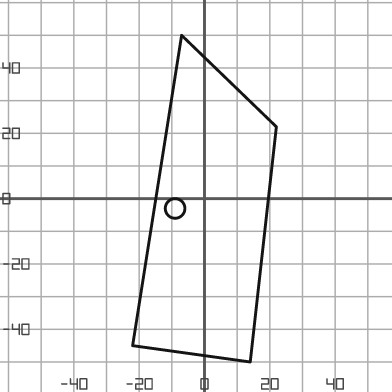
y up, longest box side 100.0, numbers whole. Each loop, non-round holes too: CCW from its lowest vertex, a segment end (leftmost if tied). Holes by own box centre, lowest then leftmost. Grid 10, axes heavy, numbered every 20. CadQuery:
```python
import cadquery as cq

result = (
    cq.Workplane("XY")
    .moveTo(14.0, -50.0)
    .lineTo(22.0, 22.0)
    .lineTo(-7.0, 50.0)
    .lineTo(-22.0, -45.0)
    .close()
    .moveTo(-9.0, -3.0)
    .circle(3.0)
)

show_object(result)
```